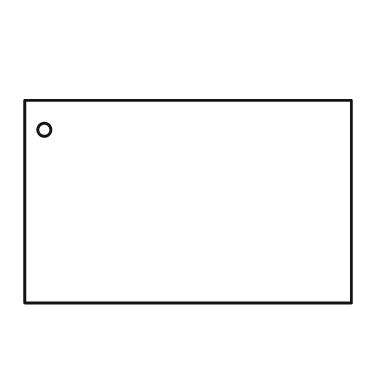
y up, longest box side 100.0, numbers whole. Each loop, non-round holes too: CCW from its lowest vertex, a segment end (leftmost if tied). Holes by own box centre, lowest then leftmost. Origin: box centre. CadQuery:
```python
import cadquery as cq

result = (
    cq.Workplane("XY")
    .moveTo(-50.0, -31.0)
    .lineTo(50.0, -31.0)
    .lineTo(50.0, 31.0)
    .lineTo(-50.0, 31.0)
    .close()
    .moveTo(-44.0, 22.0)
    .circle(2.0)
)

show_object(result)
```